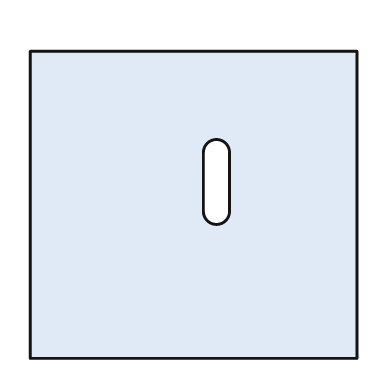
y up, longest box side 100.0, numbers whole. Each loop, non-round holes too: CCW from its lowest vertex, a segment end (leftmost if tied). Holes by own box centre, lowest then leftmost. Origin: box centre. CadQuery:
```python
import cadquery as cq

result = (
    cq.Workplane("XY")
    .moveTo(-50.0, -47.0)
    .lineTo(50.0, -47.0)
    .lineTo(50.0, 47.0)
    .lineTo(-50.0, 47.0)
    .close()
    .moveTo(3.0, -2.0)
    .threePointArc((7.0, -6.0), (11.0, -2.0))
    .lineTo(11.0, 16.0)
    .threePointArc((7.0, 20.0), (3.0, 16.0))
    .close()
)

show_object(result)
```